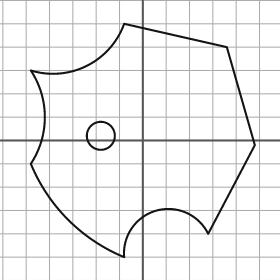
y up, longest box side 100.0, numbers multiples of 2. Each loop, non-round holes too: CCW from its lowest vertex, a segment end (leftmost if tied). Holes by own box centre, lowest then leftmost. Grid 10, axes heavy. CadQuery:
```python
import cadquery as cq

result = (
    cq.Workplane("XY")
    .moveTo(-8.0, -50.0)
    .threePointArc((6.0, -30.0), (28.0, -40.0))
    .lineTo(48.0, -2.0)
    .lineTo(36.0, 40.0)
    .lineTo(-8.0, 50.0)
    .threePointArc((-24.0, 32.0), (-48.0, 30.0))
    .threePointArc((-42.0, 10.0), (-48.0, -10.0))
    .threePointArc((-32.0, -34.0), (-8.0, -50.0))
    .close()
    .moveTo(-18.0, 2.0)
    .circle(6.0)
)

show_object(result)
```